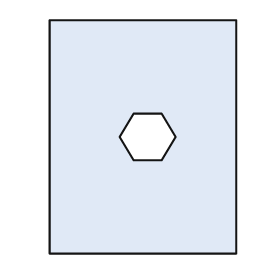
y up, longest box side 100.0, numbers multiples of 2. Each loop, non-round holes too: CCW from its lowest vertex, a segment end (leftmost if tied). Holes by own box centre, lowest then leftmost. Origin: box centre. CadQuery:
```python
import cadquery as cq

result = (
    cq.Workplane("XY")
    .moveTo(-40.0, -50.0)
    .lineTo(40.0, -50.0)
    .lineTo(40.0, 50.0)
    .lineTo(-40.0, 50.0)
    .close()
    .moveTo(-4.0, -10.0)
    .lineTo(8.0, -10.0)
    .lineTo(14.0, 0.0)
    .lineTo(8.0, 10.0)
    .lineTo(-4.0, 10.0)
    .lineTo(-10.0, 0.0)
    .close()
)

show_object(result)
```